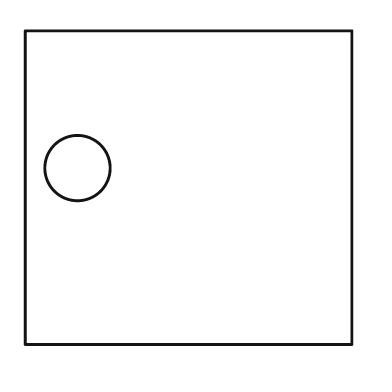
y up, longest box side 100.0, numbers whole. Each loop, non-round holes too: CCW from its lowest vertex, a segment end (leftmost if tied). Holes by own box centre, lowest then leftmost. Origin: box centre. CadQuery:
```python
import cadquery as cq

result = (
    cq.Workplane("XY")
    .moveTo(-50.0, -48.0)
    .lineTo(50.0, -48.0)
    .lineTo(50.0, 48.0)
    .lineTo(-50.0, 48.0)
    .close()
    .moveTo(-34.0, 6.0)
    .circle(10.0)
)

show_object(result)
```